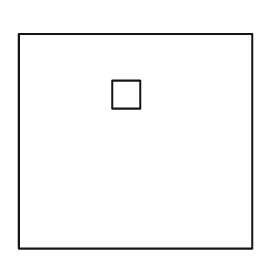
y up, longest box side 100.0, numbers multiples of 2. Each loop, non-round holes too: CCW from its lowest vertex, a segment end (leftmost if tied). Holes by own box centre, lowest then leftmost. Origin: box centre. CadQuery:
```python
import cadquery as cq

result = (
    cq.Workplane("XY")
    .moveTo(-50.0, -46.0)
    .lineTo(50.0, -46.0)
    .lineTo(50.0, 46.0)
    .lineTo(-50.0, 46.0)
    .close()
    .moveTo(-10.0, 14.0)
    .lineTo(2.0, 14.0)
    .lineTo(2.0, 26.0)
    .lineTo(-10.0, 26.0)
    .close()
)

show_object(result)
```